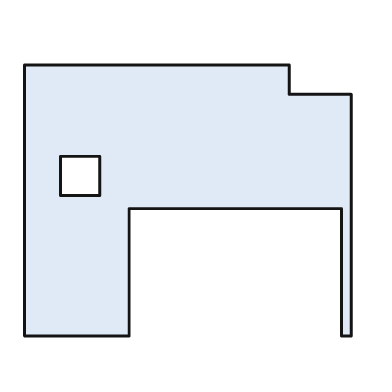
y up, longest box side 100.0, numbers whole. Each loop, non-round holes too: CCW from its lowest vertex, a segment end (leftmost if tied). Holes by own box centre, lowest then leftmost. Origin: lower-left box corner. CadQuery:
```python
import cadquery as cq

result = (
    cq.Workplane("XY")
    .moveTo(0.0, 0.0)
    .lineTo(32.0, 0.0)
    .lineTo(32.0, 39.0)
    .lineTo(97.0, 39.0)
    .lineTo(97.0, 0.0)
    .lineTo(100.0, 0.0)
    .lineTo(100.0, 74.0)
    .lineTo(81.0, 74.0)
    .lineTo(81.0, 83.0)
    .lineTo(0.0, 83.0)
    .close()
    .moveTo(11.0, 43.0)
    .lineTo(23.0, 43.0)
    .lineTo(23.0, 55.0)
    .lineTo(11.0, 55.0)
    .close()
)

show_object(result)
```